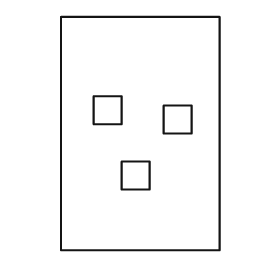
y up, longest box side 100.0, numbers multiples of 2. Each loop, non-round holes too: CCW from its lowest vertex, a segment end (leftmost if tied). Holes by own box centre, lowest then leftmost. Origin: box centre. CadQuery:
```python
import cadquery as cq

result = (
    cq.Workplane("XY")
    .moveTo(-34.0, -50.0)
    .lineTo(34.0, -50.0)
    .lineTo(34.0, 50.0)
    .lineTo(-34.0, 50.0)
    .close()
    .moveTo(-8.0, -24.0)
    .lineTo(4.0, -24.0)
    .lineTo(4.0, -12.0)
    .lineTo(-8.0, -12.0)
    .close()
    .moveTo(10.0, 0.0)
    .lineTo(22.0, 0.0)
    .lineTo(22.0, 12.0)
    .lineTo(10.0, 12.0)
    .close()
    .moveTo(-20.0, 4.0)
    .lineTo(-8.0, 4.0)
    .lineTo(-8.0, 16.0)
    .lineTo(-20.0, 16.0)
    .close()
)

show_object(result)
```